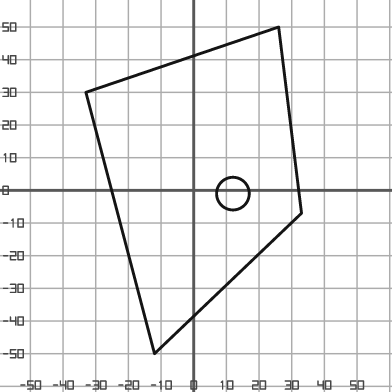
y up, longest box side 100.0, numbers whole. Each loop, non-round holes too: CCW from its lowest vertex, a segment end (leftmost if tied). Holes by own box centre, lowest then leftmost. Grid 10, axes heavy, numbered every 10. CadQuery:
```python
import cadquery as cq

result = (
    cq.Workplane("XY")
    .moveTo(-12.0, -50.0)
    .lineTo(33.0, -7.0)
    .lineTo(26.0, 50.0)
    .lineTo(-33.0, 30.0)
    .close()
    .moveTo(12.0, -1.0)
    .circle(5.0)
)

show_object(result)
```